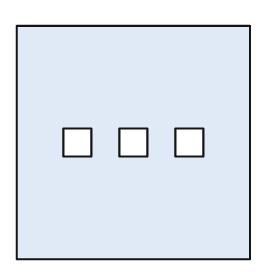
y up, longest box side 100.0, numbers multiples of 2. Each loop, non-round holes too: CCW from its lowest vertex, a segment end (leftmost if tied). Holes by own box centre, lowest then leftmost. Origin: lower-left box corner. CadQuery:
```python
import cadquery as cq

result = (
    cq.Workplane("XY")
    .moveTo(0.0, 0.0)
    .lineTo(100.0, 0.0)
    .lineTo(100.0, 100.0)
    .lineTo(0.0, 100.0)
    .close()
    .moveTo(20.0, 44.0)
    .lineTo(32.0, 44.0)
    .lineTo(32.0, 56.0)
    .lineTo(20.0, 56.0)
    .close()
    .moveTo(44.0, 44.0)
    .lineTo(56.0, 44.0)
    .lineTo(56.0, 56.0)
    .lineTo(44.0, 56.0)
    .close()
    .moveTo(68.0, 44.0)
    .lineTo(80.0, 44.0)
    .lineTo(80.0, 56.0)
    .lineTo(68.0, 56.0)
    .close()
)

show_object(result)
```